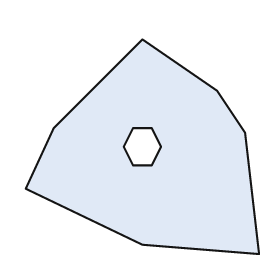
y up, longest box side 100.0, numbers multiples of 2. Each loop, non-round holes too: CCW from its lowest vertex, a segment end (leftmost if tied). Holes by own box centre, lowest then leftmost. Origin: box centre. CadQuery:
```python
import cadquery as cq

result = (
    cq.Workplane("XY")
    .moveTo(50.0, -46.0)
    .lineTo(44.0, 6.0)
    .lineTo(32.0, 24.0)
    .lineTo(0.0, 46.0)
    .lineTo(-38.0, 8.0)
    .lineTo(-50.0, -18.0)
    .lineTo(0.0, -42.0)
    .close()
    .moveTo(-4.0, -8.0)
    .lineTo(4.0, -8.0)
    .lineTo(8.0, 0.0)
    .lineTo(4.0, 8.0)
    .lineTo(-4.0, 8.0)
    .lineTo(-8.0, 0.0)
    .close()
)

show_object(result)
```